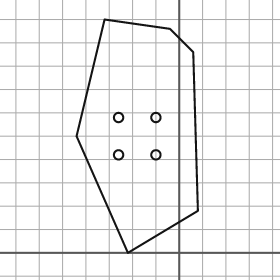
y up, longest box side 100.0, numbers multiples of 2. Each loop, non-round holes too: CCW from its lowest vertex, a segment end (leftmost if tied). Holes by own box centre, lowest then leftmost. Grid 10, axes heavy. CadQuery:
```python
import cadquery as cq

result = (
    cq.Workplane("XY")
    .moveTo(-22.0, 0.0)
    .lineTo(8.0, 18.0)
    .lineTo(6.0, 86.0)
    .lineTo(-4.0, 96.0)
    .lineTo(-32.0, 100.0)
    .lineTo(-44.0, 50.0)
    .close()
    .moveTo(-26.0, 42.0)
    .circle(2.0)
    .moveTo(-10.0, 42.0)
    .circle(2.0)
    .moveTo(-26.0, 58.0)
    .circle(2.0)
    .moveTo(-10.0, 58.0)
    .circle(2.0)
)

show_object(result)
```